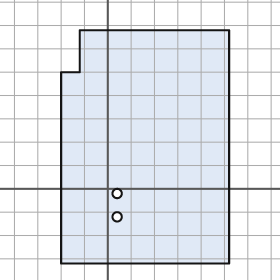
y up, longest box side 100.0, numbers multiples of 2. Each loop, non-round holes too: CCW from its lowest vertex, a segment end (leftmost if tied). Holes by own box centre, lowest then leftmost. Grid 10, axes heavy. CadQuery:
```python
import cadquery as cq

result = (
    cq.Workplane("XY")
    .moveTo(-20.0, -32.0)
    .lineTo(52.0, -32.0)
    .lineTo(52.0, 68.0)
    .lineTo(-12.0, 68.0)
    .lineTo(-12.0, 50.0)
    .lineTo(-20.0, 50.0)
    .close()
    .moveTo(4.0, -12.0)
    .circle(2.0)
    .moveTo(4.0, -2.0)
    .circle(2.0)
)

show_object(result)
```